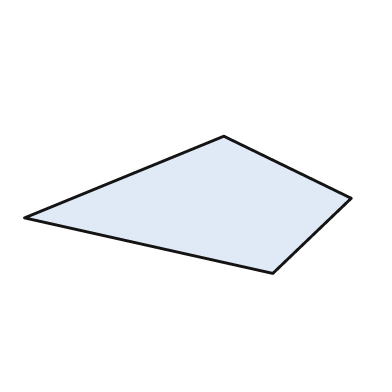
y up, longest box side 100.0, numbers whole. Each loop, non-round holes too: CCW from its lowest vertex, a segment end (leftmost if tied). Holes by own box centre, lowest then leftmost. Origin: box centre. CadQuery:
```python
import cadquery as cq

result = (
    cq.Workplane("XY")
    .moveTo(26.0, -21.0)
    .lineTo(50.0, 2.0)
    .lineTo(11.0, 21.0)
    .lineTo(-50.0, -4.0)
    .close()
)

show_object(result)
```